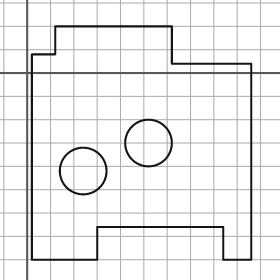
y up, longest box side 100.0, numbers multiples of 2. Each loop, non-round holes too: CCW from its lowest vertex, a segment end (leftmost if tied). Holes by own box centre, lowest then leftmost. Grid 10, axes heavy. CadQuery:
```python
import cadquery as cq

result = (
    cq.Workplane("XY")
    .moveTo(2.0, -80.0)
    .lineTo(30.0, -80.0)
    .lineTo(30.0, -66.0)
    .lineTo(84.0, -66.0)
    .lineTo(84.0, -80.0)
    .lineTo(96.0, -80.0)
    .lineTo(96.0, 4.0)
    .lineTo(62.0, 4.0)
    .lineTo(62.0, 20.0)
    .lineTo(12.0, 20.0)
    .lineTo(12.0, 8.0)
    .lineTo(2.0, 8.0)
    .close()
    .moveTo(24.0, -42.0)
    .circle(10.0)
    .moveTo(52.0, -30.0)
    .circle(10.0)
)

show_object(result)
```